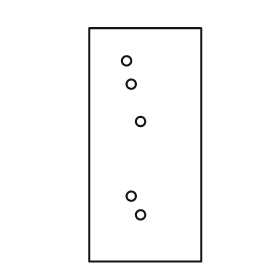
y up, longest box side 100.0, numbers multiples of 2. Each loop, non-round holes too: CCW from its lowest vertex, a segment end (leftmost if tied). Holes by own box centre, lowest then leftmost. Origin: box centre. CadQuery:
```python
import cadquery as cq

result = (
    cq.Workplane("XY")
    .moveTo(-24.0, -50.0)
    .lineTo(24.0, -50.0)
    .lineTo(24.0, 50.0)
    .lineTo(-24.0, 50.0)
    .close()
    .moveTo(-2.0, -30.0)
    .circle(2.0)
    .moveTo(-6.0, -22.0)
    .circle(2.0)
    .moveTo(-2.0, 10.0)
    .circle(2.0)
    .moveTo(-6.0, 26.0)
    .circle(2.0)
    .moveTo(-8.0, 36.0)
    .circle(2.0)
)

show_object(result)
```